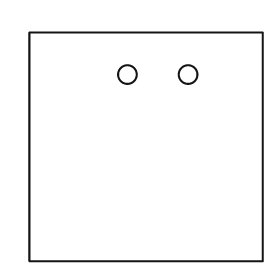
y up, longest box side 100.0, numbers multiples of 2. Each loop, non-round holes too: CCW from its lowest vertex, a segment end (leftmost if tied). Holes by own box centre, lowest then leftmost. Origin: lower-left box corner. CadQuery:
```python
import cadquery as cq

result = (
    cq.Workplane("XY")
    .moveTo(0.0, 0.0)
    .lineTo(100.0, 0.0)
    .lineTo(100.0, 98.0)
    .lineTo(0.0, 98.0)
    .close()
    .moveTo(42.0, 80.0)
    .circle(4.0)
    .moveTo(68.0, 80.0)
    .circle(4.0)
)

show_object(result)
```